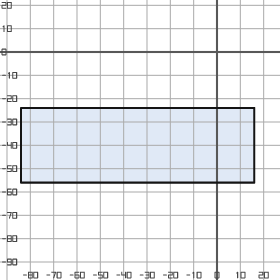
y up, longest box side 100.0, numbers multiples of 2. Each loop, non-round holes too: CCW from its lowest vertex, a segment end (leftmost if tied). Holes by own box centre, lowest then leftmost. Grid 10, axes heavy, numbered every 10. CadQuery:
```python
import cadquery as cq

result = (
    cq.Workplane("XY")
    .moveTo(-84.0, -56.0)
    .lineTo(16.0, -56.0)
    .lineTo(16.0, -24.0)
    .lineTo(-84.0, -24.0)
    .close()
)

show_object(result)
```